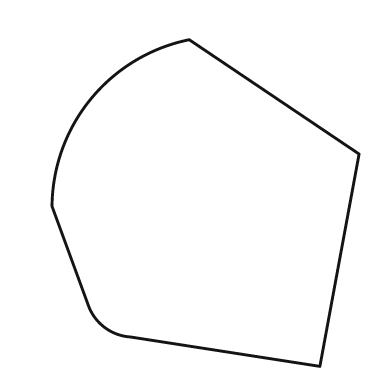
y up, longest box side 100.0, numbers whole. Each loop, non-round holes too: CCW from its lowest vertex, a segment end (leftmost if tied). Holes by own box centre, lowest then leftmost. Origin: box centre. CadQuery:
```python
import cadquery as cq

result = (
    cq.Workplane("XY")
    .moveTo(35.0, -50.0)
    .lineTo(47.0, 15.0)
    .lineTo(-5.0, 50.0)
    .threePointArc((-35.0, 32.0), (-47.0, -1.0))
    .lineTo(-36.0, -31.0)
    .threePointArc((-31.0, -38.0), (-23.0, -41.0))
    .close()
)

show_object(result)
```